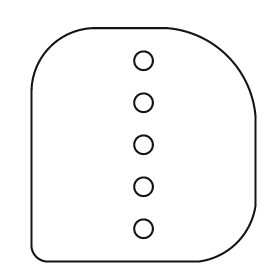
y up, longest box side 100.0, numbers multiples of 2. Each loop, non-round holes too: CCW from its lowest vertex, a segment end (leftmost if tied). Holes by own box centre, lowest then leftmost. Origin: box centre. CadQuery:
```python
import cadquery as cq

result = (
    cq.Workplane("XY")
    .moveTo(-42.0, -50.0)
    .lineTo(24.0, -50.0)
    .threePointArc((40.0, -42.0), (48.0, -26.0))
    .lineTo(48.0, 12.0)
    .threePointArc((36.0, 38.0), (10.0, 50.0))
    .lineTo(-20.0, 50.0)
    .threePointArc((-40.0, 42.0), (-48.0, 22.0))
    .lineTo(-48.0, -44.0)
    .threePointArc((-46.0, -48.0), (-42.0, -50.0))
    .close()
    .moveTo(0.0, -36.0)
    .circle(4.0)
    .moveTo(0.0, -18.0)
    .circle(4.0)
    .moveTo(0.0, 0.0)
    .circle(4.0)
    .moveTo(0.0, 18.0)
    .circle(4.0)
    .moveTo(0.0, 36.0)
    .circle(4.0)
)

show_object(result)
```